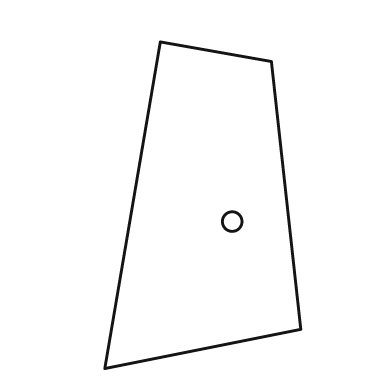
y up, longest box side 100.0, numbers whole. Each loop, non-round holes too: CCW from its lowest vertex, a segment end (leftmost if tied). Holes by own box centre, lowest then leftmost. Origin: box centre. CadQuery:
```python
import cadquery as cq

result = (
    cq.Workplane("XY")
    .moveTo(-30.0, -50.0)
    .lineTo(30.0, -38.0)
    .lineTo(21.0, 44.0)
    .lineTo(-13.0, 50.0)
    .close()
    .moveTo(9.0, -5.0)
    .circle(3.0)
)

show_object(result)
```